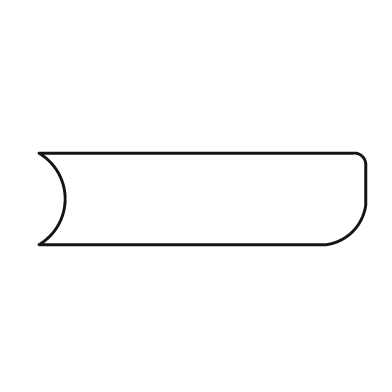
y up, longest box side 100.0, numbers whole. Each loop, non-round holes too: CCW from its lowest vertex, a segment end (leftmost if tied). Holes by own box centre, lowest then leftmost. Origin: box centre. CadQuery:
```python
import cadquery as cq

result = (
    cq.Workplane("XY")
    .moveTo(-50.0, -14.0)
    .lineTo(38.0, -14.0)
    .threePointArc((46.0, -10.0), (50.0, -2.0))
    .lineTo(50.0, 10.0)
    .threePointArc((49.0, 13.0), (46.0, 14.0))
    .lineTo(-50.0, 14.0)
    .threePointArc((-42.0, 0.0), (-50.0, -14.0))
    .close()
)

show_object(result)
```